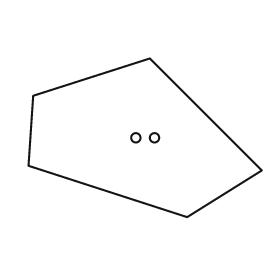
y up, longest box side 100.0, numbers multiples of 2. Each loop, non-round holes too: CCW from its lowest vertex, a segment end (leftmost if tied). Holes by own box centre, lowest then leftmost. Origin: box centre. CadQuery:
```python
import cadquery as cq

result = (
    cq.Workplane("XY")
    .moveTo(18.0, -34.0)
    .lineTo(50.0, -14.0)
    .lineTo(2.0, 34.0)
    .lineTo(-48.0, 18.0)
    .lineTo(-50.0, -12.0)
    .close()
    .moveTo(-4.0, 0.0)
    .circle(2.0)
    .moveTo(4.0, 0.0)
    .circle(2.0)
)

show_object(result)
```